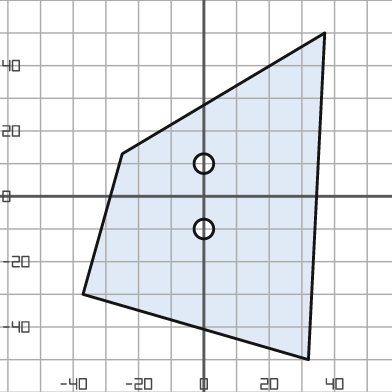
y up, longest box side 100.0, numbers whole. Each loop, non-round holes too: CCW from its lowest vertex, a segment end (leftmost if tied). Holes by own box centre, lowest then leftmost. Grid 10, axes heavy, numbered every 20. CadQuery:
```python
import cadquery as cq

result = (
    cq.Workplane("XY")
    .moveTo(32.0, -50.0)
    .lineTo(37.0, 50.0)
    .lineTo(-25.0, 13.0)
    .lineTo(-37.0, -30.0)
    .close()
    .moveTo(0.0, -10.0)
    .circle(3.0)
    .moveTo(0.0, 10.0)
    .circle(3.0)
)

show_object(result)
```